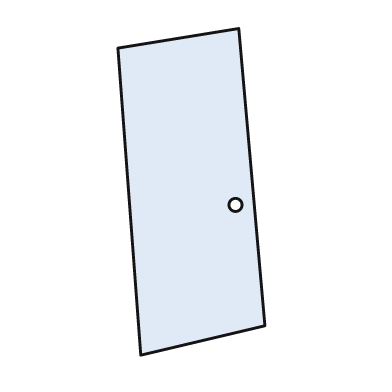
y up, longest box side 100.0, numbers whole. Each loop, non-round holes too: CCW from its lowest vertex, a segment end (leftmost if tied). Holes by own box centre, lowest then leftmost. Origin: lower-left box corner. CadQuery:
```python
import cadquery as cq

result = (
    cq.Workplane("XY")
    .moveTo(7.0, 0.0)
    .lineTo(45.0, 9.0)
    .lineTo(37.0, 100.0)
    .lineTo(0.0, 94.0)
    .close()
    .moveTo(36.0, 46.0)
    .circle(2.0)
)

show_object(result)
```